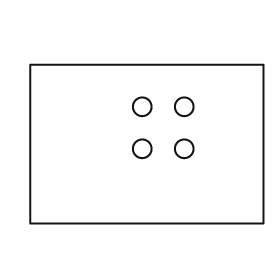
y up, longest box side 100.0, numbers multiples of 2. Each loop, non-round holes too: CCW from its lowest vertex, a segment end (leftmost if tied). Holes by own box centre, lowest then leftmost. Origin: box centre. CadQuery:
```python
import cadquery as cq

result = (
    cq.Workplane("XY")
    .moveTo(-50.0, -34.0)
    .lineTo(50.0, -34.0)
    .lineTo(50.0, 34.0)
    .lineTo(-50.0, 34.0)
    .close()
    .moveTo(-2.0, -2.0)
    .circle(4.0)
    .moveTo(16.0, -2.0)
    .circle(4.0)
    .moveTo(-2.0, 16.0)
    .circle(4.0)
    .moveTo(16.0, 16.0)
    .circle(4.0)
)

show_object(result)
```